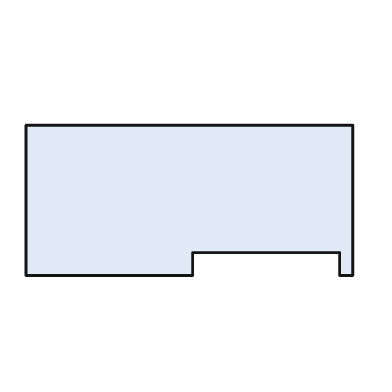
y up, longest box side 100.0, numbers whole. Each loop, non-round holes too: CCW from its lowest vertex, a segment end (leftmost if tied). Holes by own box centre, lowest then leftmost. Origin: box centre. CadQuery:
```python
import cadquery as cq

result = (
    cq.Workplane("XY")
    .moveTo(-50.0, -23.0)
    .lineTo(1.0, -23.0)
    .lineTo(1.0, -16.0)
    .lineTo(46.0, -16.0)
    .lineTo(46.0, -23.0)
    .lineTo(50.0, -23.0)
    .lineTo(50.0, 23.0)
    .lineTo(-50.0, 23.0)
    .close()
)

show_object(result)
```